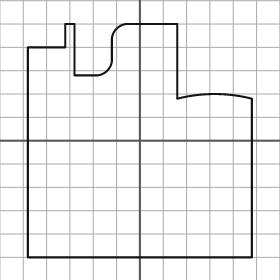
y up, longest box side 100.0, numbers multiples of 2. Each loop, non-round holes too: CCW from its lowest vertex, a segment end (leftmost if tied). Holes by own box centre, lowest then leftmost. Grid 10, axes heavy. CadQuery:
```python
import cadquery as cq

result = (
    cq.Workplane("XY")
    .moveTo(-48.0, -50.0)
    .lineTo(48.0, -50.0)
    .lineTo(48.0, 18.0)
    .threePointArc((32.0, 20.0), (16.0, 18.0))
    .lineTo(16.0, 50.0)
    .lineTo(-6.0, 50.0)
    .threePointArc((-10.0, 48.0), (-12.0, 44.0))
    .lineTo(-12.0, 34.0)
    .threePointArc((-14.0, 30.0), (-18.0, 28.0))
    .lineTo(-28.0, 28.0)
    .lineTo(-28.0, 50.0)
    .lineTo(-32.0, 50.0)
    .lineTo(-32.0, 40.0)
    .lineTo(-48.0, 40.0)
    .close()
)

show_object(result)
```